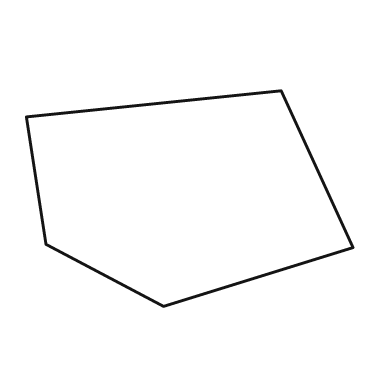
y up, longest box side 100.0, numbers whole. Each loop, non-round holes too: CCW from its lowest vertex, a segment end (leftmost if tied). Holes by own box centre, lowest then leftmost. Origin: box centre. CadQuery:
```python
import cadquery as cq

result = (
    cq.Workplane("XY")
    .moveTo(-8.0, -33.0)
    .lineTo(50.0, -15.0)
    .lineTo(28.0, 33.0)
    .lineTo(-50.0, 25.0)
    .lineTo(-44.0, -14.0)
    .close()
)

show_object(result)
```